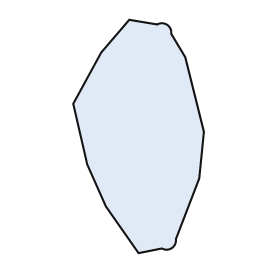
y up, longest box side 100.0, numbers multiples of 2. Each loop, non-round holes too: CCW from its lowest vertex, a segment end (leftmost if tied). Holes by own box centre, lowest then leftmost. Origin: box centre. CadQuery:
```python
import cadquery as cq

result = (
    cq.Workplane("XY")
    .moveTo(0.0, -50.0)
    .lineTo(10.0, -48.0)
    .threePointArc((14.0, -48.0), (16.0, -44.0))
    .lineTo(26.0, -18.0)
    .lineTo(28.0, 2.0)
    .lineTo(20.0, 34.0)
    .lineTo(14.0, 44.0)
    .threePointArc((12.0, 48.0), (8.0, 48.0))
    .lineTo(-4.0, 50.0)
    .lineTo(-16.0, 36.0)
    .lineTo(-28.0, 14.0)
    .lineTo(-22.0, -12.0)
    .lineTo(-14.0, -30.0)
    .close()
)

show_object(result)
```